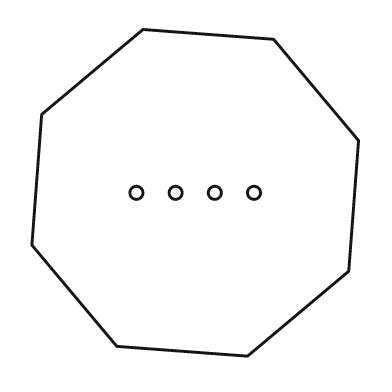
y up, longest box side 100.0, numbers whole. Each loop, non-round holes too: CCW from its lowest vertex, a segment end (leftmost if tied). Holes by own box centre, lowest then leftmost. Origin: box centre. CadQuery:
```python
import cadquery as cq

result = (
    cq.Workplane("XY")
    .moveTo(16.0, -50.0)
    .lineTo(47.0, -24.0)
    .lineTo(50.0, 16.0)
    .lineTo(24.0, 47.0)
    .lineTo(-16.0, 50.0)
    .lineTo(-47.0, 24.0)
    .lineTo(-50.0, -16.0)
    .lineTo(-24.0, -47.0)
    .close()
    .moveTo(-18.0, 0.0)
    .circle(2.0)
    .moveTo(-6.0, 0.0)
    .circle(2.0)
    .moveTo(6.0, 0.0)
    .circle(2.0)
    .moveTo(18.0, 0.0)
    .circle(2.0)
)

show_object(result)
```